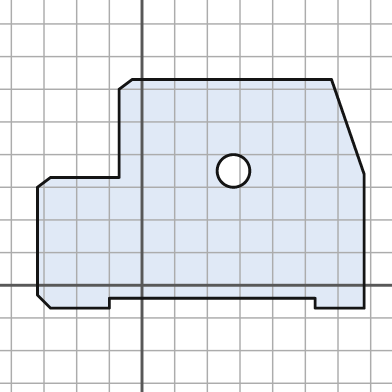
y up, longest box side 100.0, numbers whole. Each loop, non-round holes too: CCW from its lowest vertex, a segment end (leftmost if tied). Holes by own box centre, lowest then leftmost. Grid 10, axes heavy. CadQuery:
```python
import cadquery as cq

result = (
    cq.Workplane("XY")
    .moveTo(-28.0, -7.0)
    .lineTo(-10.0, -7.0)
    .lineTo(-10.0, -4.0)
    .lineTo(53.0, -4.0)
    .lineTo(53.0, -7.0)
    .lineTo(68.0, -7.0)
    .lineTo(68.0, 34.0)
    .lineTo(58.0, 63.0)
    .lineTo(-3.0, 63.0)
    .lineTo(-7.0, 60.0)
    .lineTo(-7.0, 33.0)
    .lineTo(-28.0, 33.0)
    .lineTo(-32.0, 30.0)
    .lineTo(-32.0, -3.0)
    .close()
    .moveTo(28.0, 35.0)
    .circle(5.0)
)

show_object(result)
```